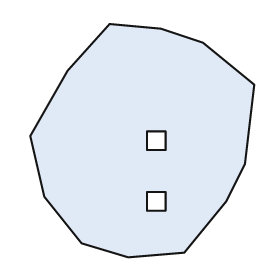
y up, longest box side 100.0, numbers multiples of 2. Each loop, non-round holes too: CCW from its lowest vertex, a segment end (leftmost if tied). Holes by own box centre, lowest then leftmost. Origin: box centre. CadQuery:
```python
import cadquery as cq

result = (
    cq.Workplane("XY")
    .moveTo(-6.0, -50.0)
    .lineTo(18.0, -48.0)
    .lineTo(36.0, -26.0)
    .lineTo(44.0, -10.0)
    .lineTo(48.0, 24.0)
    .lineTo(26.0, 42.0)
    .lineTo(8.0, 48.0)
    .lineTo(-14.0, 50.0)
    .lineTo(-32.0, 30.0)
    .lineTo(-48.0, 2.0)
    .lineTo(-42.0, -24.0)
    .lineTo(-26.0, -44.0)
    .close()
    .moveTo(2.0, -30.0)
    .lineTo(10.0, -30.0)
    .lineTo(10.0, -22.0)
    .lineTo(2.0, -22.0)
    .close()
    .moveTo(2.0, -4.0)
    .lineTo(10.0, -4.0)
    .lineTo(10.0, 4.0)
    .lineTo(2.0, 4.0)
    .close()
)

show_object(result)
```